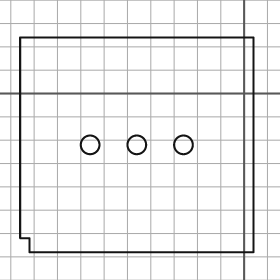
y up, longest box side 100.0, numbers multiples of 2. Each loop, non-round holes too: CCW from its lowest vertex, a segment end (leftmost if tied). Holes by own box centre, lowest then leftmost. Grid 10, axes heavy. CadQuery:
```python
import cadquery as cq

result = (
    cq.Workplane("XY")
    .moveTo(-92.0, -68.0)
    .lineTo(4.0, -68.0)
    .lineTo(4.0, 24.0)
    .lineTo(-96.0, 24.0)
    .lineTo(-96.0, -62.0)
    .lineTo(-92.0, -62.0)
    .close()
    .moveTo(-66.0, -22.0)
    .circle(4.0)
    .moveTo(-46.0, -22.0)
    .circle(4.0)
    .moveTo(-26.0, -22.0)
    .circle(4.0)
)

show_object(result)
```